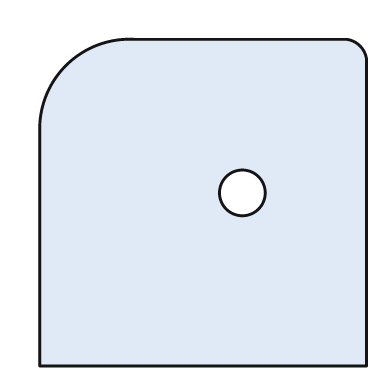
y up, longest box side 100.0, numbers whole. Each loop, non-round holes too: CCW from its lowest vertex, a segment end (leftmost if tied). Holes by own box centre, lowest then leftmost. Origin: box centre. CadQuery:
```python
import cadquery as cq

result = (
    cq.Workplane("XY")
    .moveTo(-50.0, -50.0)
    .lineTo(50.0, -50.0)
    .lineTo(50.0, 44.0)
    .threePointArc((48.0, 48.0), (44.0, 50.0))
    .lineTo(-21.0, 50.0)
    .threePointArc((-42.0, 42.0), (-50.0, 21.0))
    .close()
    .moveTo(12.0, 3.0)
    .circle(7.0)
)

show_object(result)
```